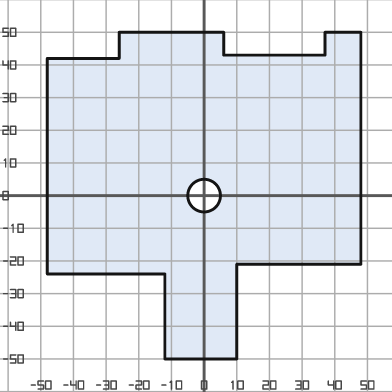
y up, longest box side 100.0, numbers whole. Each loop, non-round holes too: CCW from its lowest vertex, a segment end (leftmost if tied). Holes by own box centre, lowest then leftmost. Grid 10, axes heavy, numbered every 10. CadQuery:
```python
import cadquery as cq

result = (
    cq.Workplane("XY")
    .moveTo(-12.0, -50.0)
    .lineTo(10.0, -50.0)
    .lineTo(10.0, -21.0)
    .lineTo(48.0, -21.0)
    .lineTo(48.0, 50.0)
    .lineTo(37.0, 50.0)
    .lineTo(37.0, 43.0)
    .lineTo(6.0, 43.0)
    .lineTo(6.0, 50.0)
    .lineTo(-26.0, 50.0)
    .lineTo(-26.0, 42.0)
    .lineTo(-48.0, 42.0)
    .lineTo(-48.0, -24.0)
    .lineTo(-12.0, -24.0)
    .close()
    .moveTo(0.0, 0.0)
    .circle(5.0)
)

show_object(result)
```